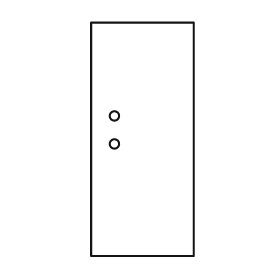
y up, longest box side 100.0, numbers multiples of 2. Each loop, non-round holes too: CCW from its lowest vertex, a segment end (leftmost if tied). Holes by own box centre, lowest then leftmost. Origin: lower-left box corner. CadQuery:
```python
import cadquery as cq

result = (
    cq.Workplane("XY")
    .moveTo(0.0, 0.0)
    .lineTo(44.0, 0.0)
    .lineTo(44.0, 100.0)
    .lineTo(0.0, 100.0)
    .close()
    .moveTo(10.0, 48.0)
    .circle(2.0)
    .moveTo(10.0, 60.0)
    .circle(2.0)
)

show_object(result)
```